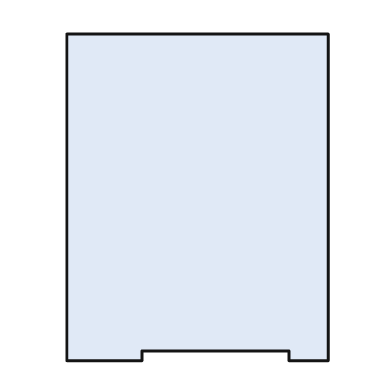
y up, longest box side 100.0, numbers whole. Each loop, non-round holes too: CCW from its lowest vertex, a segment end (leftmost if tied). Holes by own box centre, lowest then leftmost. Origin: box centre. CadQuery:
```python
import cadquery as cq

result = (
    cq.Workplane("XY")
    .moveTo(-40.0, -50.0)
    .lineTo(-17.0, -50.0)
    .lineTo(-17.0, -47.0)
    .lineTo(28.0, -47.0)
    .lineTo(28.0, -50.0)
    .lineTo(40.0, -50.0)
    .lineTo(40.0, 50.0)
    .lineTo(-40.0, 50.0)
    .close()
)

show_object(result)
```